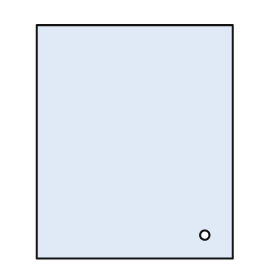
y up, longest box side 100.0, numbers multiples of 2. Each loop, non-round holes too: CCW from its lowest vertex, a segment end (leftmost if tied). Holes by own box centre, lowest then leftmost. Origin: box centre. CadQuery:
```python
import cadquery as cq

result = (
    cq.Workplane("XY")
    .moveTo(-42.0, -50.0)
    .lineTo(42.0, -50.0)
    .lineTo(42.0, 50.0)
    .lineTo(-42.0, 50.0)
    .close()
    .moveTo(30.0, -40.0)
    .circle(2.0)
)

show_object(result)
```